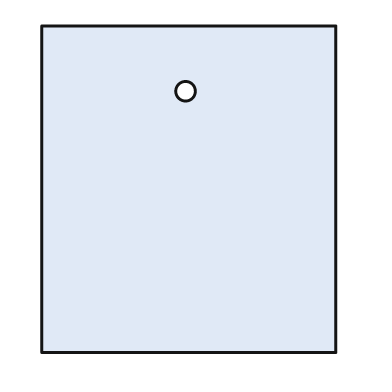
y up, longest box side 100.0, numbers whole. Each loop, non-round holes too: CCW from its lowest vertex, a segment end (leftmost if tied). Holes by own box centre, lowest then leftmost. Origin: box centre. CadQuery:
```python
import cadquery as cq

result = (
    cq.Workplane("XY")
    .moveTo(-45.0, -50.0)
    .lineTo(45.0, -50.0)
    .lineTo(45.0, 50.0)
    .lineTo(-45.0, 50.0)
    .close()
    .moveTo(-1.0, 30.0)
    .circle(3.0)
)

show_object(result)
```